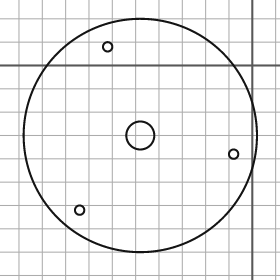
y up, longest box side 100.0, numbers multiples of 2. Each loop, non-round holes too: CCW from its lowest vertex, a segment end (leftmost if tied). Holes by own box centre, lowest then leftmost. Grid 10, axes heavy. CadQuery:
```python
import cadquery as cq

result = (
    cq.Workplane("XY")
    .moveTo(-48.0, -30.0)
    .circle(50.0)
    .moveTo(-74.0, -62.0)
    .circle(2.0)
    .moveTo(-8.0, -38.0)
    .circle(2.0)
    .moveTo(-48.0, -30.0)
    .circle(6.0)
    .moveTo(-62.0, 8.0)
    .circle(2.0)
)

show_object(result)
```